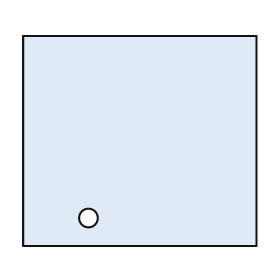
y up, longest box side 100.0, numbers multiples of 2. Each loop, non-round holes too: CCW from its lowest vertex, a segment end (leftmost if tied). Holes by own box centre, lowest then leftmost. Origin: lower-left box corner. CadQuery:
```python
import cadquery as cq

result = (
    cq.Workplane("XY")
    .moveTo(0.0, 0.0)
    .lineTo(100.0, 0.0)
    .lineTo(100.0, 90.0)
    .lineTo(0.0, 90.0)
    .close()
    .moveTo(28.0, 12.0)
    .circle(4.0)
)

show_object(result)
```